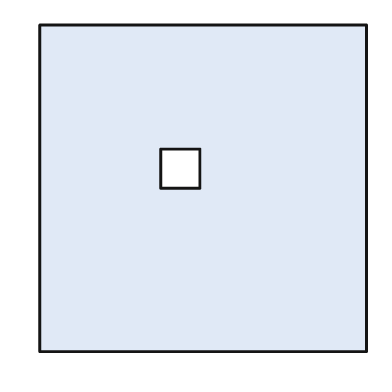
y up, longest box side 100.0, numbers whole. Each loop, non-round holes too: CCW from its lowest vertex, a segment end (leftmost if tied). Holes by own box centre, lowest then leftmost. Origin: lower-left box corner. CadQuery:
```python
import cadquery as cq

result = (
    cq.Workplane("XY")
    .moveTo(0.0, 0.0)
    .lineTo(100.0, 0.0)
    .lineTo(100.0, 100.0)
    .lineTo(0.0, 100.0)
    .close()
    .moveTo(37.0, 50.0)
    .lineTo(49.0, 50.0)
    .lineTo(49.0, 62.0)
    .lineTo(37.0, 62.0)
    .close()
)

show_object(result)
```